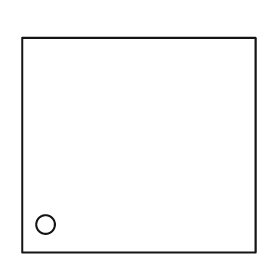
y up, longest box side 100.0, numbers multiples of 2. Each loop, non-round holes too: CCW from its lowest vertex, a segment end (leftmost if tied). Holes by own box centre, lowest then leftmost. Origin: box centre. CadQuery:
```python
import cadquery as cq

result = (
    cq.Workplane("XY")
    .moveTo(-50.0, -46.0)
    .lineTo(50.0, -46.0)
    .lineTo(50.0, 46.0)
    .lineTo(-50.0, 46.0)
    .close()
    .moveTo(-40.0, -34.0)
    .circle(4.0)
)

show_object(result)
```